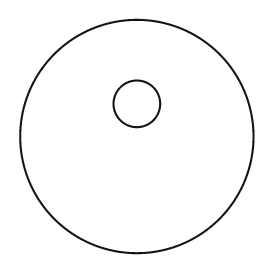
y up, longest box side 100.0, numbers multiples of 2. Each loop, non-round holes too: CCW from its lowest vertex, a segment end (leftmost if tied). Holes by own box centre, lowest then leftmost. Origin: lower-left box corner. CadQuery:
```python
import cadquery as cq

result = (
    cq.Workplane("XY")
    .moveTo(50.0, 50.0)
    .circle(50.0)
    .moveTo(50.0, 64.0)
    .circle(10.0)
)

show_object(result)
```